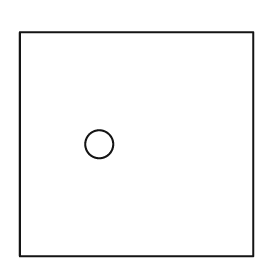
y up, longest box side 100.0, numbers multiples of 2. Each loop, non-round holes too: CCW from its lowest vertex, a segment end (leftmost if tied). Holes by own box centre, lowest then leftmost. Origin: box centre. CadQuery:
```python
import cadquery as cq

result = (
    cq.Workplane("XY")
    .moveTo(-50.0, -48.0)
    .lineTo(50.0, -48.0)
    .lineTo(50.0, 48.0)
    .lineTo(-50.0, 48.0)
    .close()
    .moveTo(-16.0, 0.0)
    .circle(6.0)
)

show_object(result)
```